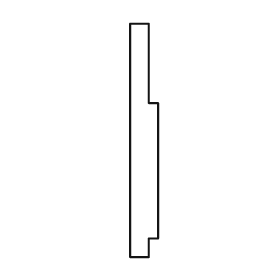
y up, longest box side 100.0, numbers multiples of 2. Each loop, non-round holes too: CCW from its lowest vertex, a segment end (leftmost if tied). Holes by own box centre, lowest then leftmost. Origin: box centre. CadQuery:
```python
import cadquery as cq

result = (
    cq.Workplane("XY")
    .moveTo(-6.0, -50.0)
    .lineTo(2.0, -50.0)
    .lineTo(2.0, -42.0)
    .lineTo(6.0, -42.0)
    .lineTo(6.0, 16.0)
    .lineTo(2.0, 16.0)
    .lineTo(2.0, 50.0)
    .lineTo(-6.0, 50.0)
    .close()
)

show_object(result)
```